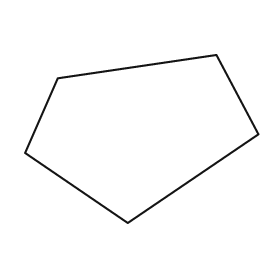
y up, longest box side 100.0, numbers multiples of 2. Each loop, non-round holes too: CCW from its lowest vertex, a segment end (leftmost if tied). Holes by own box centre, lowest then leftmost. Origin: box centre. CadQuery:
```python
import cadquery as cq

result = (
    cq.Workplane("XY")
    .moveTo(-6.0, -36.0)
    .lineTo(50.0, 2.0)
    .lineTo(32.0, 36.0)
    .lineTo(-36.0, 26.0)
    .lineTo(-50.0, -6.0)
    .close()
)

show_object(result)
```